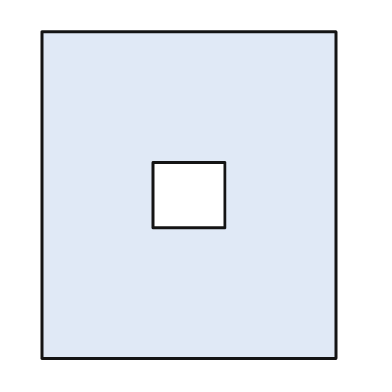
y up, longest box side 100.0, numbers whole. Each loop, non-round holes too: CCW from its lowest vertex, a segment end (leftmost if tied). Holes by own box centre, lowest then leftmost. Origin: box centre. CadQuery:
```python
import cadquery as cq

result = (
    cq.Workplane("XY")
    .moveTo(-45.0, -50.0)
    .lineTo(45.0, -50.0)
    .lineTo(45.0, 50.0)
    .lineTo(-45.0, 50.0)
    .close()
    .moveTo(-11.0, -10.0)
    .lineTo(11.0, -10.0)
    .lineTo(11.0, 10.0)
    .lineTo(-11.0, 10.0)
    .close()
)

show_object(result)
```